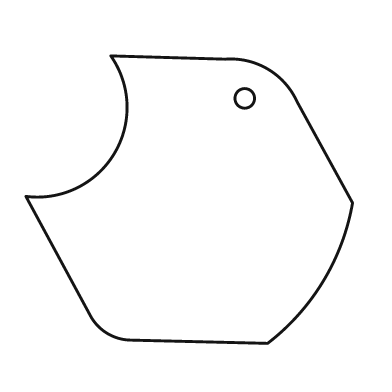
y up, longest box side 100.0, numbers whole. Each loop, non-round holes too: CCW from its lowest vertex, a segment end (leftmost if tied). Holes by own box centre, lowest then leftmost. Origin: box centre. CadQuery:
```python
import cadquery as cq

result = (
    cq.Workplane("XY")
    .moveTo(24.0, -44.0)
    .threePointArc((41.0, -25.0), (50.0, -1.0))
    .lineTo(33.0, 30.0)
    .threePointArc((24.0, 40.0), (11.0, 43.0))
    .lineTo(-24.0, 44.0)
    .threePointArc((-23.0, 14.0), (-50.0, 1.0))
    .lineTo(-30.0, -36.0)
    .threePointArc((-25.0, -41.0), (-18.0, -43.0))
    .close()
    .moveTo(17.0, 31.0)
    .circle(3.0)
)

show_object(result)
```